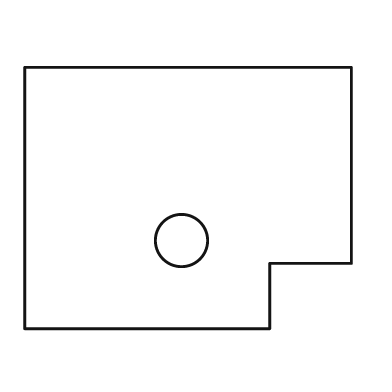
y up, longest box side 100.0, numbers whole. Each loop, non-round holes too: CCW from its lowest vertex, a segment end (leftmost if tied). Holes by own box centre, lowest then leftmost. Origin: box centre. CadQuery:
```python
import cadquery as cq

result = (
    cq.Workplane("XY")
    .moveTo(-50.0, -40.0)
    .lineTo(25.0, -40.0)
    .lineTo(25.0, -20.0)
    .lineTo(50.0, -20.0)
    .lineTo(50.0, 40.0)
    .lineTo(-50.0, 40.0)
    .close()
    .moveTo(-2.0, -13.0)
    .circle(8.0)
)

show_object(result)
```